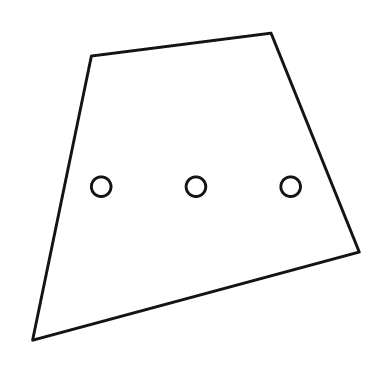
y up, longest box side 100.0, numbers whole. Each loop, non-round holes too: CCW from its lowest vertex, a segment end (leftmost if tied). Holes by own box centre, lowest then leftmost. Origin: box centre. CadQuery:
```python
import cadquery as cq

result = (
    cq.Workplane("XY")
    .moveTo(-50.0, -47.0)
    .lineTo(50.0, -20.0)
    .lineTo(23.0, 47.0)
    .lineTo(-32.0, 40.0)
    .close()
    .moveTo(-29.0, 0.0)
    .circle(3.0)
    .moveTo(0.0, 0.0)
    .circle(3.0)
    .moveTo(29.0, 0.0)
    .circle(3.0)
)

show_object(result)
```